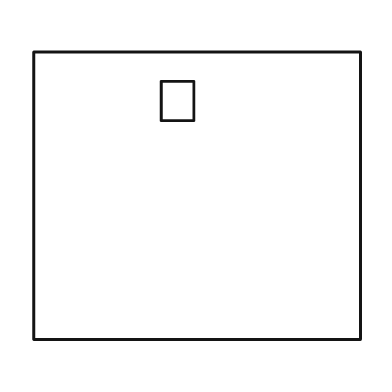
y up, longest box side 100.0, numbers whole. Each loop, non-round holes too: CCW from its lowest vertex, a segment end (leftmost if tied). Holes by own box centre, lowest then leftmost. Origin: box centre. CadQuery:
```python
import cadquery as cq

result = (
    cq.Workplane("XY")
    .moveTo(-50.0, -44.0)
    .lineTo(50.0, -44.0)
    .lineTo(50.0, 44.0)
    .lineTo(-50.0, 44.0)
    .close()
    .moveTo(-11.0, 23.0)
    .lineTo(-1.0, 23.0)
    .lineTo(-1.0, 35.0)
    .lineTo(-11.0, 35.0)
    .close()
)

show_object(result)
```